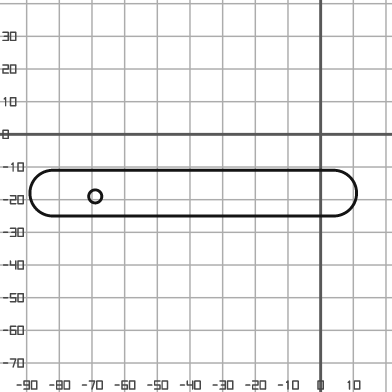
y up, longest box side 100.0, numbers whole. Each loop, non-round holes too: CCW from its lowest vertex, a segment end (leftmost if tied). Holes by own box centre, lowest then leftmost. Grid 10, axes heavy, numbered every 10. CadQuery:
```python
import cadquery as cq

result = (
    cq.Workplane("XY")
    .moveTo(-82.0, -25.0)
    .lineTo(4.0, -25.0)
    .threePointArc((11.0, -18.0), (4.0, -11.0))
    .lineTo(-82.0, -11.0)
    .threePointArc((-89.0, -18.0), (-82.0, -25.0))
    .close()
    .moveTo(-69.0, -19.0)
    .circle(2.0)
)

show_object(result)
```